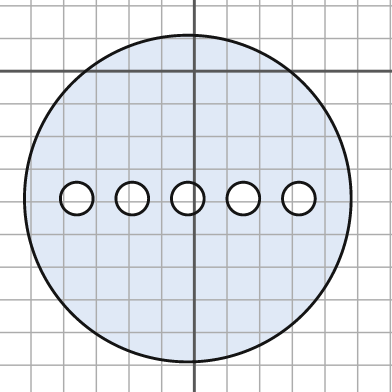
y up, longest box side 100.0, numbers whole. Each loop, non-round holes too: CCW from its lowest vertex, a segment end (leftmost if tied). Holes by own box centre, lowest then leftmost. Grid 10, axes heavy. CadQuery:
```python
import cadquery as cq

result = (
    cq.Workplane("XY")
    .moveTo(-2.0, -39.0)
    .circle(50.0)
    .moveTo(-36.0, -39.0)
    .circle(5.0)
    .moveTo(-19.0, -39.0)
    .circle(5.0)
    .moveTo(-2.0, -39.0)
    .circle(5.0)
    .moveTo(15.0, -39.0)
    .circle(5.0)
    .moveTo(32.0, -39.0)
    .circle(5.0)
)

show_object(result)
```